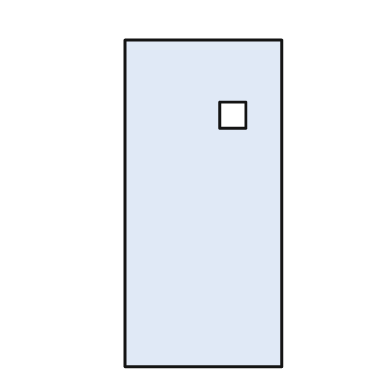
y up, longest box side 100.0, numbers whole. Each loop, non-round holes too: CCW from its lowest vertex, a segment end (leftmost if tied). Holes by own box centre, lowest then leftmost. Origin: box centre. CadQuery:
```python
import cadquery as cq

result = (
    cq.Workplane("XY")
    .moveTo(-24.0, -50.0)
    .lineTo(24.0, -50.0)
    .lineTo(24.0, 50.0)
    .lineTo(-24.0, 50.0)
    .close()
    .moveTo(5.0, 23.0)
    .lineTo(13.0, 23.0)
    .lineTo(13.0, 31.0)
    .lineTo(5.0, 31.0)
    .close()
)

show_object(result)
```